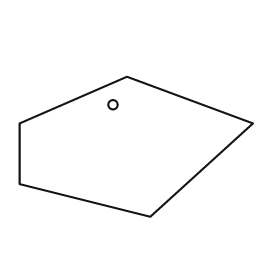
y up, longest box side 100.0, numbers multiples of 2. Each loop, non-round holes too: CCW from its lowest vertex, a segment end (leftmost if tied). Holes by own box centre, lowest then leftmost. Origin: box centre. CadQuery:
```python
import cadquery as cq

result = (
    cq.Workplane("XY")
    .moveTo(6.0, -30.0)
    .lineTo(50.0, 10.0)
    .lineTo(-4.0, 30.0)
    .lineTo(-50.0, 10.0)
    .lineTo(-50.0, -16.0)
    .close()
    .moveTo(-10.0, 18.0)
    .circle(2.0)
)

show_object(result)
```